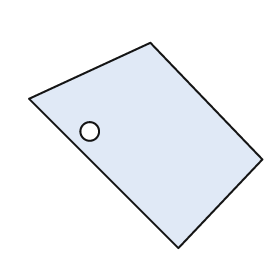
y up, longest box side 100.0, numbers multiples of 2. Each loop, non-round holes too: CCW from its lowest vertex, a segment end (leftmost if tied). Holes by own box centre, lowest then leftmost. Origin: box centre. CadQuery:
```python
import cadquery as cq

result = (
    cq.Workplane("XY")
    .moveTo(14.0, -44.0)
    .lineTo(50.0, -6.0)
    .lineTo(2.0, 44.0)
    .lineTo(-50.0, 20.0)
    .close()
    .moveTo(-24.0, 6.0)
    .circle(4.0)
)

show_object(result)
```